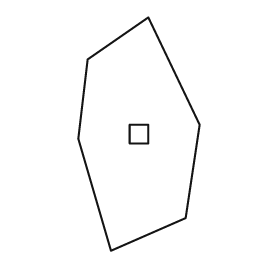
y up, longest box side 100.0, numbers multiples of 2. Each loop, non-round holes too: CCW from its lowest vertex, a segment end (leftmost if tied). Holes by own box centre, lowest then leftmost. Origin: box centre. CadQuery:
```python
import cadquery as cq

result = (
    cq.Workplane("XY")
    .moveTo(-12.0, -50.0)
    .lineTo(20.0, -36.0)
    .lineTo(26.0, 4.0)
    .lineTo(4.0, 50.0)
    .lineTo(-22.0, 32.0)
    .lineTo(-26.0, -2.0)
    .close()
    .moveTo(-4.0, -4.0)
    .lineTo(4.0, -4.0)
    .lineTo(4.0, 4.0)
    .lineTo(-4.0, 4.0)
    .close()
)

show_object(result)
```